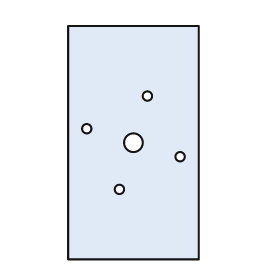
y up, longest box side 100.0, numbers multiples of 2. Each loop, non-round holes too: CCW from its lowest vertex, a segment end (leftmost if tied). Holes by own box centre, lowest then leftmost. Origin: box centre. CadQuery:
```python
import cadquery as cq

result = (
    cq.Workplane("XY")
    .moveTo(-28.0, -50.0)
    .lineTo(28.0, -50.0)
    .lineTo(28.0, 50.0)
    .lineTo(-28.0, 50.0)
    .close()
    .moveTo(-6.0, -20.0)
    .circle(2.0)
    .moveTo(20.0, -6.0)
    .circle(2.0)
    .moveTo(0.0, 0.0)
    .circle(4.0)
    .moveTo(-20.0, 6.0)
    .circle(2.0)
    .moveTo(6.0, 20.0)
    .circle(2.0)
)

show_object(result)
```